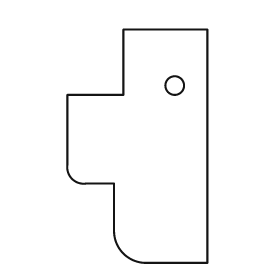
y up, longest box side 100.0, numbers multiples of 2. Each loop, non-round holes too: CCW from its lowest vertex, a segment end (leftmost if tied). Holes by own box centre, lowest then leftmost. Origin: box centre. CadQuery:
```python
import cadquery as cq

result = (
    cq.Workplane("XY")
    .moveTo(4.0, -50.0)
    .lineTo(30.0, -50.0)
    .lineTo(30.0, 50.0)
    .lineTo(-6.0, 50.0)
    .lineTo(-6.0, 22.0)
    .lineTo(-30.0, 22.0)
    .lineTo(-30.0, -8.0)
    .threePointArc((-28.0, -14.0), (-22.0, -16.0))
    .lineTo(-10.0, -16.0)
    .lineTo(-10.0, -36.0)
    .threePointArc((-6.0, -46.0), (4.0, -50.0))
    .close()
    .moveTo(16.0, 26.0)
    .circle(4.0)
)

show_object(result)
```